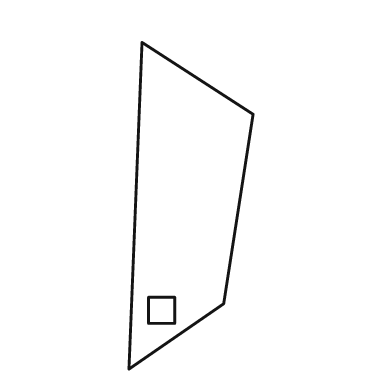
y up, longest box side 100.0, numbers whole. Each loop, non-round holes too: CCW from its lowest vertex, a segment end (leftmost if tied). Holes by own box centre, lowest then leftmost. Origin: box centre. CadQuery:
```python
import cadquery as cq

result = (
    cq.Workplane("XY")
    .moveTo(-19.0, -50.0)
    .lineTo(10.0, -30.0)
    .lineTo(19.0, 28.0)
    .lineTo(-15.0, 50.0)
    .close()
    .moveTo(-13.0, -36.0)
    .lineTo(-5.0, -36.0)
    .lineTo(-5.0, -28.0)
    .lineTo(-13.0, -28.0)
    .close()
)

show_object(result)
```